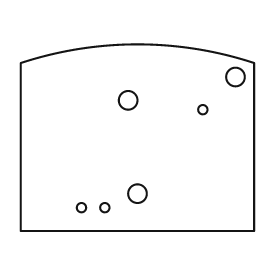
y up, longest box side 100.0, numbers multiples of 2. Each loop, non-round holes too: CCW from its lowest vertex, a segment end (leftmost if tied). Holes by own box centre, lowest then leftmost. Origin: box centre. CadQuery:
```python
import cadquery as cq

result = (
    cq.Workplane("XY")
    .moveTo(-50.0, -40.0)
    .lineTo(50.0, -40.0)
    .lineTo(50.0, 32.0)
    .threePointArc((0.0, 40.0), (-50.0, 32.0))
    .close()
    .moveTo(-24.0, -30.0)
    .circle(2.0)
    .moveTo(-14.0, -30.0)
    .circle(2.0)
    .moveTo(0.0, -24.0)
    .circle(4.0)
    .moveTo(28.0, 12.0)
    .circle(2.0)
    .moveTo(-4.0, 16.0)
    .circle(4.0)
    .moveTo(42.0, 26.0)
    .circle(4.0)
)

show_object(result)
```